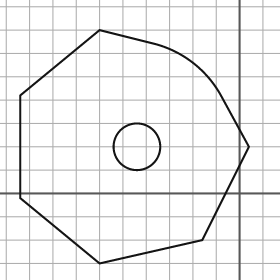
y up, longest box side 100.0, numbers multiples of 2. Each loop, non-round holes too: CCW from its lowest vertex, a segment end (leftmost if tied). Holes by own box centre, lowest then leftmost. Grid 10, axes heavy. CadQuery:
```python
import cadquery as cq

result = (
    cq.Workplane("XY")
    .moveTo(-60.0, -30.0)
    .lineTo(-16.0, -20.0)
    .lineTo(4.0, 20.0)
    .lineTo(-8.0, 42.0)
    .threePointArc((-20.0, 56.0), (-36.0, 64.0))
    .lineTo(-60.0, 70.0)
    .lineTo(-94.0, 42.0)
    .lineTo(-94.0, -2.0)
    .close()
    .moveTo(-44.0, 20.0)
    .circle(10.0)
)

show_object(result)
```